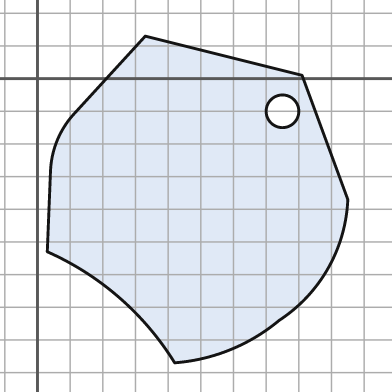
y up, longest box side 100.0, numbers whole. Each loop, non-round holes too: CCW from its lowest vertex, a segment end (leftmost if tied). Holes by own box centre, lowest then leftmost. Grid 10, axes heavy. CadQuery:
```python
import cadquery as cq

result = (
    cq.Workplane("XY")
    .moveTo(42.0, -87.0)
    .threePointArc((59.0, -83.0), (74.0, -74.0))
    .threePointArc((89.0, -58.0), (95.0, -37.0))
    .lineTo(81.0, 1.0)
    .lineTo(33.0, 13.0)
    .lineTo(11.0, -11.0)
    .threePointArc((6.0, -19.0), (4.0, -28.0))
    .lineTo(3.0, -53.0)
    .threePointArc((25.0, -67.0), (42.0, -87.0))
    .close()
    .moveTo(75.0, -10.0)
    .circle(5.0)
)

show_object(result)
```